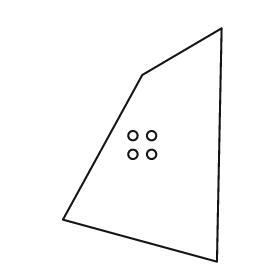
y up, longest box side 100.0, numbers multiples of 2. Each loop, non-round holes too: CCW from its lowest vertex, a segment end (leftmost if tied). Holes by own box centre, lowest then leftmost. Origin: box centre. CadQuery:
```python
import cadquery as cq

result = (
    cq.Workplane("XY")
    .moveTo(32.0, -50.0)
    .lineTo(34.0, 50.0)
    .lineTo(0.0, 30.0)
    .lineTo(-34.0, -32.0)
    .close()
    .moveTo(-4.0, -4.0)
    .circle(2.0)
    .moveTo(4.0, -4.0)
    .circle(2.0)
    .moveTo(-4.0, 4.0)
    .circle(2.0)
    .moveTo(4.0, 4.0)
    .circle(2.0)
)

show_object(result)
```